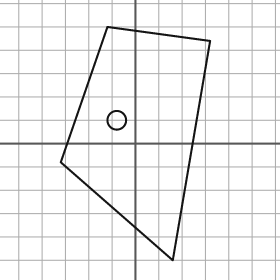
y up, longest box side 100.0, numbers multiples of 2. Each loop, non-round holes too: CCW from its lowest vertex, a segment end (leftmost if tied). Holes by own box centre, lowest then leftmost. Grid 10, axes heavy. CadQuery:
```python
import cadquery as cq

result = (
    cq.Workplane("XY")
    .moveTo(16.0, -50.0)
    .lineTo(32.0, 44.0)
    .lineTo(-12.0, 50.0)
    .lineTo(-32.0, -8.0)
    .close()
    .moveTo(-8.0, 10.0)
    .circle(4.0)
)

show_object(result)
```